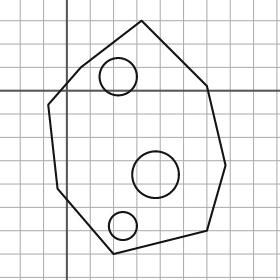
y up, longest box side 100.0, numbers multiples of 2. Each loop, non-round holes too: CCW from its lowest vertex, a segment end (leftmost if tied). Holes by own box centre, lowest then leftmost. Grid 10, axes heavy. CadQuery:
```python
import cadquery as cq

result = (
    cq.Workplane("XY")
    .moveTo(20.0, -70.0)
    .lineTo(60.0, -60.0)
    .lineTo(68.0, -32.0)
    .lineTo(60.0, 2.0)
    .lineTo(32.0, 30.0)
    .lineTo(6.0, 10.0)
    .lineTo(-8.0, -6.0)
    .lineTo(-4.0, -42.0)
    .close()
    .moveTo(24.0, -58.0)
    .circle(6.0)
    .moveTo(38.0, -36.0)
    .circle(10.0)
    .moveTo(22.0, 6.0)
    .circle(8.0)
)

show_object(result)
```